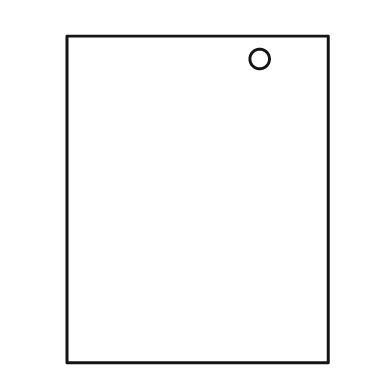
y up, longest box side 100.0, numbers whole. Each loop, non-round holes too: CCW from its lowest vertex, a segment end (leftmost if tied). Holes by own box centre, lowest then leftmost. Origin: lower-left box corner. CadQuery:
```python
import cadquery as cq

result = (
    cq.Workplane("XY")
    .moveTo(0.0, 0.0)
    .lineTo(80.0, 0.0)
    .lineTo(80.0, 100.0)
    .lineTo(0.0, 100.0)
    .close()
    .moveTo(59.0, 93.0)
    .circle(3.0)
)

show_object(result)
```